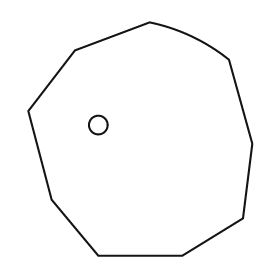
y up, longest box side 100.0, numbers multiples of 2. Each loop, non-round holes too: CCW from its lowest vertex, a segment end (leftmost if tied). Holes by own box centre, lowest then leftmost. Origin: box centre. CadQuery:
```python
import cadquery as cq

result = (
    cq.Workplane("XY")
    .moveTo(-18.0, -50.0)
    .lineTo(18.0, -50.0)
    .lineTo(44.0, -34.0)
    .lineTo(48.0, -2.0)
    .lineTo(38.0, 34.0)
    .threePointArc((22.0, 44.0), (4.0, 50.0))
    .lineTo(-28.0, 38.0)
    .lineTo(-48.0, 12.0)
    .lineTo(-38.0, -26.0)
    .close()
    .moveTo(-18.0, 6.0)
    .circle(4.0)
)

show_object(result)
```